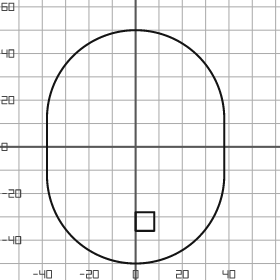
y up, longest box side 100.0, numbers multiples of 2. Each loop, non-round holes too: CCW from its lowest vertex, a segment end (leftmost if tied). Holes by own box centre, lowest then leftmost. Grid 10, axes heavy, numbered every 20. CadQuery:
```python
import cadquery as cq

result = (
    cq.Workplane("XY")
    .moveTo(-38.0, -12.0)
    .threePointArc((0.0, -50.0), (38.0, -12.0))
    .lineTo(38.0, 12.0)
    .threePointArc((0.0, 50.0), (-38.0, 12.0))
    .close()
    .moveTo(0.0, -36.0)
    .lineTo(8.0, -36.0)
    .lineTo(8.0, -28.0)
    .lineTo(0.0, -28.0)
    .close()
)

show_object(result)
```